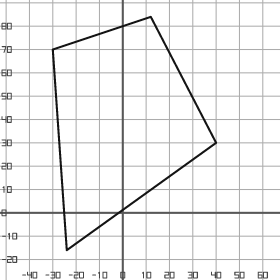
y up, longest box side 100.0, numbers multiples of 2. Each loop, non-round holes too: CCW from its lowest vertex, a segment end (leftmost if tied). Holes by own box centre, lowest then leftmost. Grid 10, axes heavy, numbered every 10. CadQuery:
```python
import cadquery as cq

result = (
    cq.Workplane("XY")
    .moveTo(-24.0, -16.0)
    .lineTo(40.0, 30.0)
    .lineTo(12.0, 84.0)
    .lineTo(-30.0, 70.0)
    .close()
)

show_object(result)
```